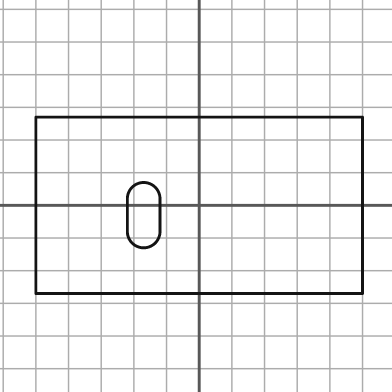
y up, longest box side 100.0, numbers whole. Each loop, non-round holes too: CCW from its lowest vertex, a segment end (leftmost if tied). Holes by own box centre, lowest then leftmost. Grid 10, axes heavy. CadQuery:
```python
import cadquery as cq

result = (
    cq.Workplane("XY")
    .moveTo(-50.0, -27.0)
    .lineTo(50.0, -27.0)
    .lineTo(50.0, 27.0)
    .lineTo(-50.0, 27.0)
    .close()
    .moveTo(-22.0, -8.0)
    .threePointArc((-17.0, -13.0), (-12.0, -8.0))
    .lineTo(-12.0, 2.0)
    .threePointArc((-17.0, 7.0), (-22.0, 2.0))
    .close()
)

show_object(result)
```